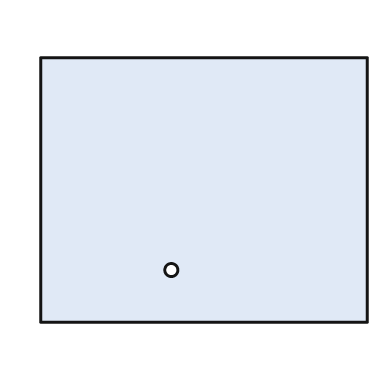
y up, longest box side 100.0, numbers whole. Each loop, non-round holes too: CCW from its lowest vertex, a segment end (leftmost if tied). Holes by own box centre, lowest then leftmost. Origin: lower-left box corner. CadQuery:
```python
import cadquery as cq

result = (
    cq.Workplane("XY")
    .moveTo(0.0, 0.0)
    .lineTo(100.0, 0.0)
    .lineTo(100.0, 81.0)
    .lineTo(0.0, 81.0)
    .close()
    .moveTo(40.0, 16.0)
    .circle(2.0)
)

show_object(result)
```